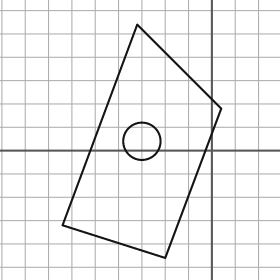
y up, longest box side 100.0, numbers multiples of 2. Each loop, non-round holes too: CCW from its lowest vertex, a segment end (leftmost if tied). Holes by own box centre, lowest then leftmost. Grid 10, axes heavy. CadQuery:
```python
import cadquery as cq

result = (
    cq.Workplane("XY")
    .moveTo(-20.0, -46.0)
    .lineTo(4.0, 18.0)
    .lineTo(-32.0, 54.0)
    .lineTo(-64.0, -32.0)
    .close()
    .moveTo(-30.0, 4.0)
    .circle(8.0)
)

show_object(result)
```